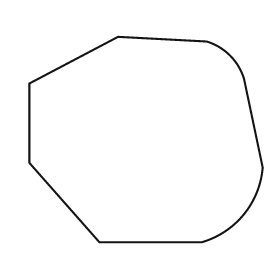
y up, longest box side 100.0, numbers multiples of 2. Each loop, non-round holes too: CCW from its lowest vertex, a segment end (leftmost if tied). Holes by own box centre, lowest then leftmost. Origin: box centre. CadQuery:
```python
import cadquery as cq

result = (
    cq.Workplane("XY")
    .moveTo(-20.0, -44.0)
    .lineTo(24.0, -44.0)
    .threePointArc((42.0, -32.0), (50.0, -12.0))
    .lineTo(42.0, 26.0)
    .threePointArc((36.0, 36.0), (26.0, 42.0))
    .lineTo(-12.0, 44.0)
    .lineTo(-50.0, 24.0)
    .lineTo(-50.0, -10.0)
    .close()
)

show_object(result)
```